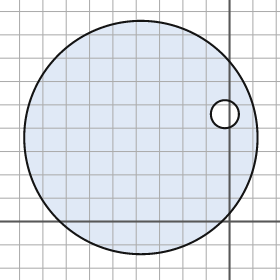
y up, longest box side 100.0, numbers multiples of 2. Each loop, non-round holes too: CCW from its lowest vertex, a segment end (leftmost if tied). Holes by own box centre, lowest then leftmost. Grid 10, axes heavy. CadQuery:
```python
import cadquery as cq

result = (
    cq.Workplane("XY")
    .moveTo(-38.0, 36.0)
    .circle(50.0)
    .moveTo(-2.0, 46.0)
    .circle(6.0)
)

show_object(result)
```